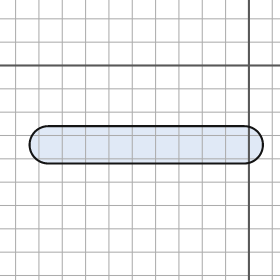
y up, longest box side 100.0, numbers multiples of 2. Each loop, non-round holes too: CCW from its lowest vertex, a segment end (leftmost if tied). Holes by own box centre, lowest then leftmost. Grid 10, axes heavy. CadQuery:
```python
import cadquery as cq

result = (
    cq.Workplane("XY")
    .moveTo(-86.0, -42.0)
    .lineTo(-2.0, -42.0)
    .threePointArc((6.0, -34.0), (-2.0, -26.0))
    .lineTo(-86.0, -26.0)
    .threePointArc((-94.0, -34.0), (-86.0, -42.0))
    .close()
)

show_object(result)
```